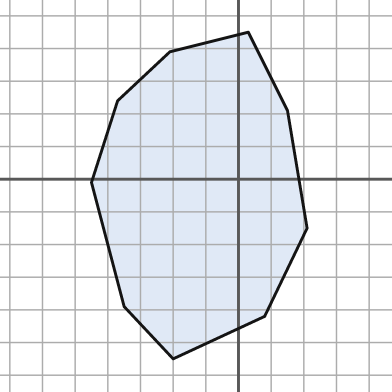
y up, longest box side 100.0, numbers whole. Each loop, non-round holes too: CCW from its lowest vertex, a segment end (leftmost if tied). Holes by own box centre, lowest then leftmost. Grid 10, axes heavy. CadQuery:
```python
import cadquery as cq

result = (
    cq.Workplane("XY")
    .moveTo(-20.0, -55.0)
    .lineTo(8.0, -42.0)
    .lineTo(21.0, -15.0)
    .lineTo(15.0, 21.0)
    .lineTo(3.0, 45.0)
    .lineTo(-21.0, 39.0)
    .lineTo(-37.0, 24.0)
    .lineTo(-45.0, -1.0)
    .lineTo(-35.0, -39.0)
    .close()
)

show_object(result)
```